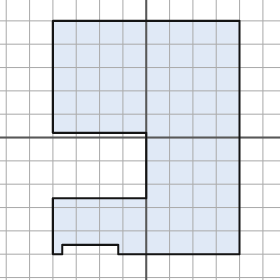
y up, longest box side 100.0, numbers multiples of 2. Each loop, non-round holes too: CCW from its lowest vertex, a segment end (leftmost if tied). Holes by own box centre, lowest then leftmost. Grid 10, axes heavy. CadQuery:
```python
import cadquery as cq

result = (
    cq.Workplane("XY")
    .moveTo(-40.0, -50.0)
    .lineTo(-36.0, -50.0)
    .lineTo(-36.0, -46.0)
    .lineTo(-12.0, -46.0)
    .lineTo(-12.0, -50.0)
    .lineTo(40.0, -50.0)
    .lineTo(40.0, 50.0)
    .lineTo(-40.0, 50.0)
    .lineTo(-40.0, 2.0)
    .lineTo(0.0, 2.0)
    .lineTo(0.0, -26.0)
    .lineTo(-40.0, -26.0)
    .close()
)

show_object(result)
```